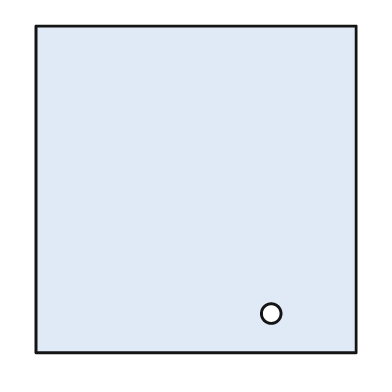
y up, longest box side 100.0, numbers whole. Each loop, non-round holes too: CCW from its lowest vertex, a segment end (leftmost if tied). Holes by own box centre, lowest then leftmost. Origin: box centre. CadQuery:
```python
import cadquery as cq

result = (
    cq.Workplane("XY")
    .moveTo(-49.0, -50.0)
    .lineTo(49.0, -50.0)
    .lineTo(49.0, 50.0)
    .lineTo(-49.0, 50.0)
    .close()
    .moveTo(23.0, -38.0)
    .circle(3.0)
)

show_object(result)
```